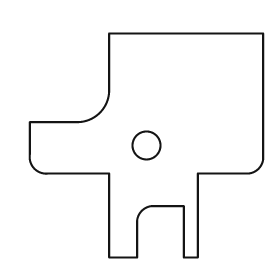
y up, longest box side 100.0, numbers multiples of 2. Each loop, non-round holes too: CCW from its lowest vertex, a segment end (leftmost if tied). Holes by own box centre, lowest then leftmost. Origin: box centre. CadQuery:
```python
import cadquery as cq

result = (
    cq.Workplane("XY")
    .moveTo(-16.0, -48.0)
    .lineTo(-4.0, -48.0)
    .lineTo(-4.0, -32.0)
    .threePointArc((-2.0, -28.0), (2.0, -26.0))
    .lineTo(16.0, -26.0)
    .lineTo(16.0, -48.0)
    .lineTo(22.0, -48.0)
    .lineTo(22.0, -12.0)
    .lineTo(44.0, -12.0)
    .threePointArc((48.0, -10.0), (50.0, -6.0))
    .lineTo(50.0, 48.0)
    .lineTo(-16.0, 48.0)
    .lineTo(-16.0, 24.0)
    .threePointArc((-20.0, 14.0), (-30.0, 10.0))
    .lineTo(-50.0, 10.0)
    .lineTo(-50.0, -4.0)
    .threePointArc((-48.0, -10.0), (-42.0, -12.0))
    .lineTo(-16.0, -12.0)
    .close()
    .moveTo(0.0, 0.0)
    .circle(6.0)
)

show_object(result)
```